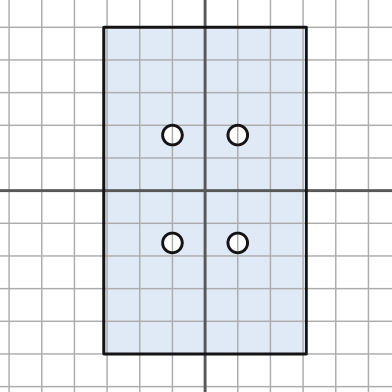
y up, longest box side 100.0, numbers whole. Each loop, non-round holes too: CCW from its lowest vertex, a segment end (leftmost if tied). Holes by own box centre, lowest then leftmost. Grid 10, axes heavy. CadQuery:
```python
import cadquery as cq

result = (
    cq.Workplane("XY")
    .moveTo(-31.0, -50.0)
    .lineTo(31.0, -50.0)
    .lineTo(31.0, 50.0)
    .lineTo(-31.0, 50.0)
    .close()
    .moveTo(-10.0, -16.0)
    .circle(3.0)
    .moveTo(10.0, -16.0)
    .circle(3.0)
    .moveTo(-10.0, 17.0)
    .circle(3.0)
    .moveTo(10.0, 17.0)
    .circle(3.0)
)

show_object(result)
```